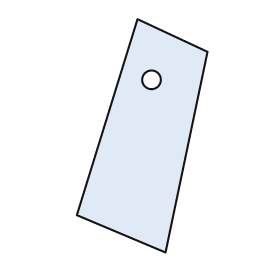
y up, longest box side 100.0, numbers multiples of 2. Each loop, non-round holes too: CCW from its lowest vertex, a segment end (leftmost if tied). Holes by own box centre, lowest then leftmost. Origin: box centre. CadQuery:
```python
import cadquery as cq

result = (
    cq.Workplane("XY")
    .moveTo(10.0, -50.0)
    .lineTo(28.0, 36.0)
    .lineTo(-2.0, 50.0)
    .lineTo(-28.0, -34.0)
    .close()
    .moveTo(4.0, 24.0)
    .circle(4.0)
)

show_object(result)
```